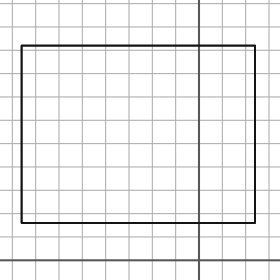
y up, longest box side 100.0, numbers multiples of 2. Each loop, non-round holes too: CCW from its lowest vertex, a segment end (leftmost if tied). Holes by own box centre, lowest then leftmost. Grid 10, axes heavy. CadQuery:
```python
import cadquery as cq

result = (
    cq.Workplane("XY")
    .moveTo(-76.0, 16.0)
    .lineTo(24.0, 16.0)
    .lineTo(24.0, 92.0)
    .lineTo(-76.0, 92.0)
    .close()
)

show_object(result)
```